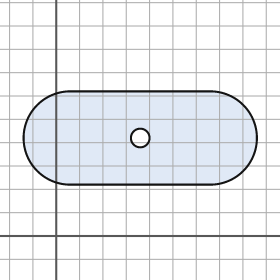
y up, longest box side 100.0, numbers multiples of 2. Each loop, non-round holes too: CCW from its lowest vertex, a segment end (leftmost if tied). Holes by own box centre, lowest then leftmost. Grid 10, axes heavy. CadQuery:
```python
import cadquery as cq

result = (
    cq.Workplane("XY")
    .moveTo(6.0, 22.0)
    .lineTo(66.0, 22.0)
    .threePointArc((86.0, 42.0), (66.0, 62.0))
    .lineTo(6.0, 62.0)
    .threePointArc((-14.0, 42.0), (6.0, 22.0))
    .close()
    .moveTo(36.0, 42.0)
    .circle(4.0)
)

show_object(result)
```